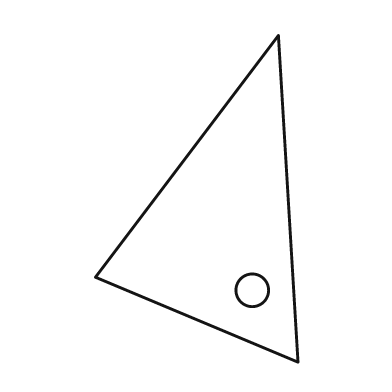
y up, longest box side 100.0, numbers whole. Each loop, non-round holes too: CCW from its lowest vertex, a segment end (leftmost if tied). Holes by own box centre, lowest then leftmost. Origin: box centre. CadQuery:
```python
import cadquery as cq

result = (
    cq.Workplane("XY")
    .moveTo(31.0, -50.0)
    .lineTo(25.0, 50.0)
    .lineTo(-31.0, -24.0)
    .close()
    .moveTo(17.0, -28.0)
    .circle(5.0)
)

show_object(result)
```